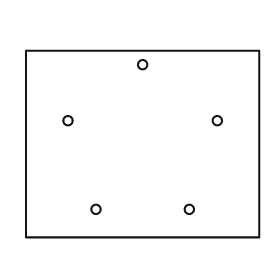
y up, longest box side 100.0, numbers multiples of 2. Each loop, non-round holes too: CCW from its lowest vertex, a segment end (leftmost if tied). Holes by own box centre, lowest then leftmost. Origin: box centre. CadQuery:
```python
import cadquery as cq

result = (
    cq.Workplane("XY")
    .moveTo(-50.0, -40.0)
    .lineTo(50.0, -40.0)
    .lineTo(50.0, 40.0)
    .lineTo(-50.0, 40.0)
    .close()
    .moveTo(-20.0, -28.0)
    .circle(2.0)
    .moveTo(20.0, -28.0)
    .circle(2.0)
    .moveTo(-32.0, 10.0)
    .circle(2.0)
    .moveTo(32.0, 10.0)
    .circle(2.0)
    .moveTo(0.0, 34.0)
    .circle(2.0)
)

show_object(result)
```